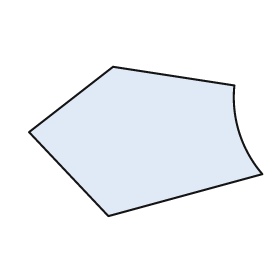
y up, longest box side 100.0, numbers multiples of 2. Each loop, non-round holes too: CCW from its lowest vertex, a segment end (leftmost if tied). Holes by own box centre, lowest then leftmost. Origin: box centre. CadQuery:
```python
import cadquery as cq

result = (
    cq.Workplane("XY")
    .moveTo(-16.0, -32.0)
    .lineTo(50.0, -14.0)
    .threePointArc((40.0, 4.0), (38.0, 24.0))
    .lineTo(-14.0, 32.0)
    .lineTo(-50.0, 4.0)
    .close()
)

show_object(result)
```